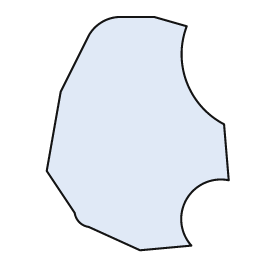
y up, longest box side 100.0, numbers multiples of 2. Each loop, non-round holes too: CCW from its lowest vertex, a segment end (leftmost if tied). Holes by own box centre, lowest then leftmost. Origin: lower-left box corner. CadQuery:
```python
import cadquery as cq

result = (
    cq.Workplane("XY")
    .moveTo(40.0, 0.0)
    .lineTo(62.0, 2.0)
    .threePointArc((60.0, 22.0), (78.0, 30.0))
    .lineTo(76.0, 54.0)
    .threePointArc((60.0, 72.0), (60.0, 96.0))
    .lineTo(46.0, 100.0)
    .lineTo(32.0, 100.0)
    .threePointArc((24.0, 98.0), (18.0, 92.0))
    .lineTo(6.0, 68.0)
    .lineTo(0.0, 34.0)
    .lineTo(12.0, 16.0)
    .threePointArc((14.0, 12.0), (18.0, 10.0))
    .close()
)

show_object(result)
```